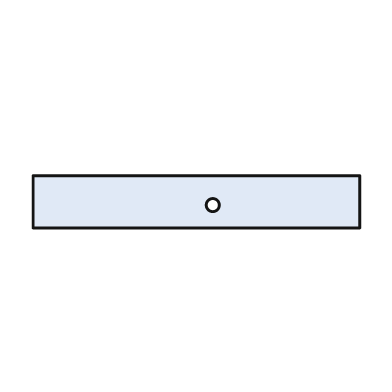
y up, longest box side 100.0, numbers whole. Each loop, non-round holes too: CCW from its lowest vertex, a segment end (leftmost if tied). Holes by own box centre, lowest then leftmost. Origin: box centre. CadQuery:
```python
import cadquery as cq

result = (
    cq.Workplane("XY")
    .moveTo(-50.0, -8.0)
    .lineTo(50.0, -8.0)
    .lineTo(50.0, 8.0)
    .lineTo(-50.0, 8.0)
    .close()
    .moveTo(5.0, -1.0)
    .circle(2.0)
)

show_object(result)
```